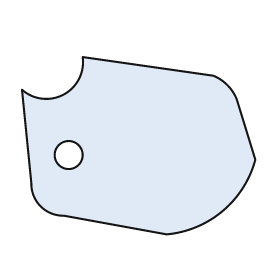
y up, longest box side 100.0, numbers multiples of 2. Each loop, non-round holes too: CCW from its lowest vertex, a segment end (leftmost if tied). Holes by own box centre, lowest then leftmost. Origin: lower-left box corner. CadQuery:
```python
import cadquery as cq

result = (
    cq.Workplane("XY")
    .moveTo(62.0, 0.0)
    .threePointArc((86.0, 10.0), (100.0, 32.0))
    .lineTo(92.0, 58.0)
    .threePointArc((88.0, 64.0), (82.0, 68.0))
    .lineTo(26.0, 76.0)
    .threePointArc((18.0, 60.0), (0.0, 62.0))
    .lineTo(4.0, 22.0)
    .threePointArc((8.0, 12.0), (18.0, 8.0))
    .close()
    .moveTo(20.0, 34.0)
    .circle(6.0)
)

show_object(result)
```